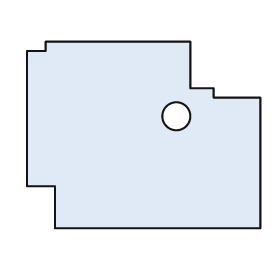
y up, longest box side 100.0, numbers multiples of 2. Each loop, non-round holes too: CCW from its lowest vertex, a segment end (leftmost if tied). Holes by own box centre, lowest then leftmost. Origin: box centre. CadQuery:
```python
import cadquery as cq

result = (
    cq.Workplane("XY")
    .moveTo(-38.0, -40.0)
    .lineTo(50.0, -40.0)
    .lineTo(50.0, 16.0)
    .lineTo(30.0, 16.0)
    .lineTo(30.0, 20.0)
    .lineTo(20.0, 20.0)
    .lineTo(20.0, 40.0)
    .lineTo(-42.0, 40.0)
    .lineTo(-42.0, 36.0)
    .lineTo(-50.0, 36.0)
    .lineTo(-50.0, -22.0)
    .lineTo(-38.0, -22.0)
    .close()
    .moveTo(14.0, 8.0)
    .circle(6.0)
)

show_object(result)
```